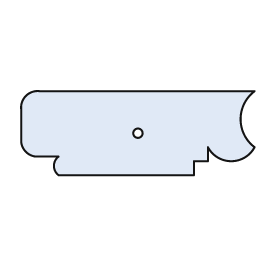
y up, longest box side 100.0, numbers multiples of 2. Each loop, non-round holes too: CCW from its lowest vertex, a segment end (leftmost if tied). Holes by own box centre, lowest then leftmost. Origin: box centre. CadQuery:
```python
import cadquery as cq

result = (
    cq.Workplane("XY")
    .moveTo(-34.0, -18.0)
    .lineTo(24.0, -18.0)
    .lineTo(24.0, -12.0)
    .lineTo(30.0, -12.0)
    .lineTo(30.0, -6.0)
    .threePointArc((40.0, -12.0), (50.0, -6.0))
    .threePointArc((44.0, 6.0), (50.0, 18.0))
    .lineTo(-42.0, 18.0)
    .threePointArc((-48.0, 16.0), (-50.0, 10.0))
    .lineTo(-50.0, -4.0)
    .threePointArc((-48.0, -8.0), (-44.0, -10.0))
    .lineTo(-34.0, -10.0)
    .threePointArc((-36.0, -14.0), (-34.0, -18.0))
    .close()
    .moveTo(0.0, 0.0)
    .circle(2.0)
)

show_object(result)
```